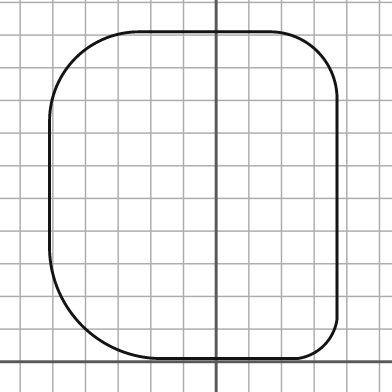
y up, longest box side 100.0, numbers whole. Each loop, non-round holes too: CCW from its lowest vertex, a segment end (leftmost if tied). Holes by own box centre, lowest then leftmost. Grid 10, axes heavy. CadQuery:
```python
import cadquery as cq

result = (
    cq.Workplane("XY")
    .moveTo(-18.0, 1.0)
    .lineTo(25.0, 1.0)
    .threePointArc((33.0, 5.0), (37.0, 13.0))
    .lineTo(37.0, 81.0)
    .threePointArc((31.0, 95.0), (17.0, 101.0))
    .lineTo(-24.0, 101.0)
    .threePointArc((-43.0, 93.0), (-51.0, 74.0))
    .lineTo(-51.0, 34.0)
    .threePointArc((-41.0, 11.0), (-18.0, 1.0))
    .close()
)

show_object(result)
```